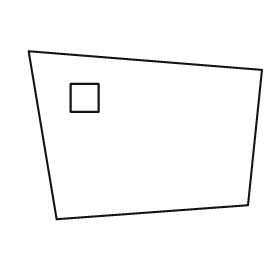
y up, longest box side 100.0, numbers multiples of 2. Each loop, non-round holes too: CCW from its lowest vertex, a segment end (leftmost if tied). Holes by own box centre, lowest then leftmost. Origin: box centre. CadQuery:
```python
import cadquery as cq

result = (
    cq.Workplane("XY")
    .moveTo(-38.0, -36.0)
    .lineTo(44.0, -30.0)
    .lineTo(50.0, 28.0)
    .lineTo(-50.0, 36.0)
    .close()
    .moveTo(-32.0, 10.0)
    .lineTo(-20.0, 10.0)
    .lineTo(-20.0, 22.0)
    .lineTo(-32.0, 22.0)
    .close()
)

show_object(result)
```